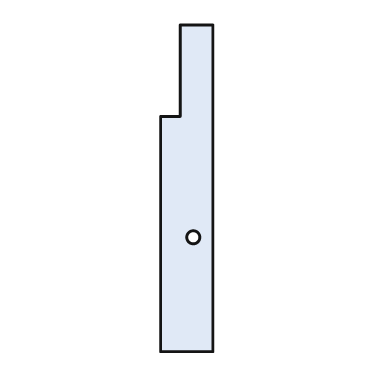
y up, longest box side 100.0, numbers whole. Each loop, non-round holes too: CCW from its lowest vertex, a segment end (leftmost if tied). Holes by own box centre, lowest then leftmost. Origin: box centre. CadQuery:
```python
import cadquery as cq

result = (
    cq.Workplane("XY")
    .moveTo(-8.0, -50.0)
    .lineTo(8.0, -50.0)
    .lineTo(8.0, 50.0)
    .lineTo(-2.0, 50.0)
    .lineTo(-2.0, 22.0)
    .lineTo(-8.0, 22.0)
    .close()
    .moveTo(2.0, -15.0)
    .circle(2.0)
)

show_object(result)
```